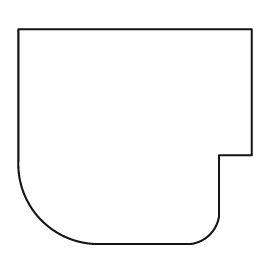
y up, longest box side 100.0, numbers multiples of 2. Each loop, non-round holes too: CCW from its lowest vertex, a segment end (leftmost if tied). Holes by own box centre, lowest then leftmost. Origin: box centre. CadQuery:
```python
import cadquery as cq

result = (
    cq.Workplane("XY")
    .moveTo(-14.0, -46.0)
    .lineTo(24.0, -46.0)
    .threePointArc((32.0, -42.0), (36.0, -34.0))
    .lineTo(36.0, -8.0)
    .lineTo(50.0, -8.0)
    .lineTo(50.0, 46.0)
    .lineTo(-50.0, 46.0)
    .lineTo(-50.0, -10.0)
    .threePointArc((-40.0, -36.0), (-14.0, -46.0))
    .close()
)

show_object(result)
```